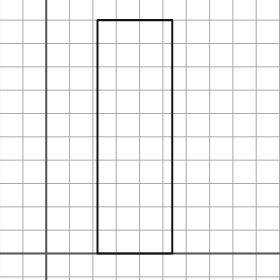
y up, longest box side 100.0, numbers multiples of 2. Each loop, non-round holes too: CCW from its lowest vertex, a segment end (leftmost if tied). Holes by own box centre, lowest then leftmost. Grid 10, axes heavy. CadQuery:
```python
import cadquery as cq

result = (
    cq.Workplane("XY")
    .moveTo(22.0, 0.0)
    .lineTo(54.0, 0.0)
    .lineTo(54.0, 100.0)
    .lineTo(22.0, 100.0)
    .close()
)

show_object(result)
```